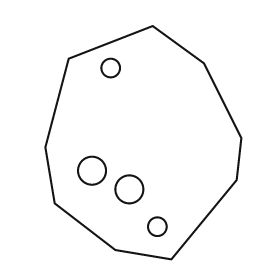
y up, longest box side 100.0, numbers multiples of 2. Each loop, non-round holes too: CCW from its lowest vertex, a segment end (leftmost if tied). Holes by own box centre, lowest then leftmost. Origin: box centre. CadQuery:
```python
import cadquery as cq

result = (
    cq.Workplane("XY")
    .moveTo(12.0, -50.0)
    .lineTo(40.0, -16.0)
    .lineTo(42.0, 2.0)
    .lineTo(26.0, 34.0)
    .lineTo(4.0, 50.0)
    .lineTo(-32.0, 36.0)
    .lineTo(-42.0, -2.0)
    .lineTo(-38.0, -26.0)
    .lineTo(-12.0, -46.0)
    .close()
    .moveTo(6.0, -36.0)
    .circle(4.0)
    .moveTo(-6.0, -20.0)
    .circle(6.0)
    .moveTo(-22.0, -12.0)
    .circle(6.0)
    .moveTo(-14.0, 32.0)
    .circle(4.0)
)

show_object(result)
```